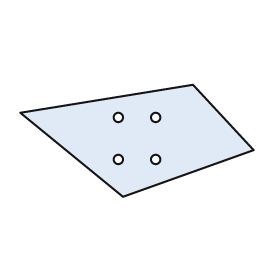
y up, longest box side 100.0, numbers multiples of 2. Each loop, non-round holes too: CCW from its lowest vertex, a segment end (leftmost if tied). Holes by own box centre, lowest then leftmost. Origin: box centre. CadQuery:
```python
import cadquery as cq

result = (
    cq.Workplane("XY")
    .moveTo(-6.0, -24.0)
    .lineTo(50.0, -4.0)
    .lineTo(24.0, 24.0)
    .lineTo(-50.0, 12.0)
    .close()
    .moveTo(-8.0, -8.0)
    .circle(2.0)
    .moveTo(8.0, -8.0)
    .circle(2.0)
    .moveTo(-8.0, 10.0)
    .circle(2.0)
    .moveTo(8.0, 10.0)
    .circle(2.0)
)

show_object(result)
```